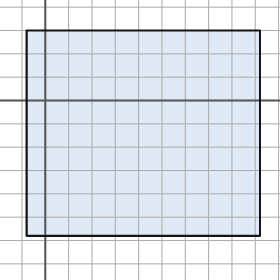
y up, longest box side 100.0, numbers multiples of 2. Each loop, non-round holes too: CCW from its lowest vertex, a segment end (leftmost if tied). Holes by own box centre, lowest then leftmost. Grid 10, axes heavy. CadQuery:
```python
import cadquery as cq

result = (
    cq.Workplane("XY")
    .moveTo(-8.0, -58.0)
    .lineTo(92.0, -58.0)
    .lineTo(92.0, 30.0)
    .lineTo(-8.0, 30.0)
    .close()
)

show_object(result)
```